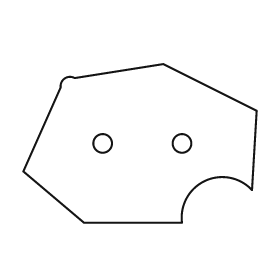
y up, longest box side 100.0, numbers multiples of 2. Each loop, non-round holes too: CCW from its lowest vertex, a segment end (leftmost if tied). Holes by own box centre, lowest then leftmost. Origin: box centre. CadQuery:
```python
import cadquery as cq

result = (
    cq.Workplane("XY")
    .moveTo(-24.0, -34.0)
    .lineTo(18.0, -34.0)
    .threePointArc((28.0, -16.0), (48.0, -20.0))
    .lineTo(50.0, 14.0)
    .lineTo(10.0, 34.0)
    .lineTo(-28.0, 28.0)
    .threePointArc((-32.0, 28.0), (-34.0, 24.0))
    .lineTo(-50.0, -12.0)
    .close()
    .moveTo(-16.0, 0.0)
    .circle(4.0)
    .moveTo(18.0, 0.0)
    .circle(4.0)
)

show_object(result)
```